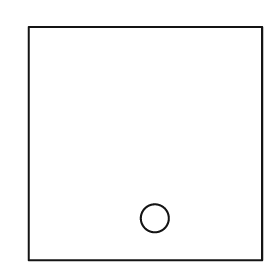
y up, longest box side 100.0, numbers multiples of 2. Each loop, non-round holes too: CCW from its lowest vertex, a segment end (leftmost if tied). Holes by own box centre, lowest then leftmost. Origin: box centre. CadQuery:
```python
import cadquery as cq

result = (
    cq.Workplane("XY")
    .moveTo(-50.0, -50.0)
    .lineTo(50.0, -50.0)
    .lineTo(50.0, 50.0)
    .lineTo(-50.0, 50.0)
    .close()
    .moveTo(4.0, -32.0)
    .circle(6.0)
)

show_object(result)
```